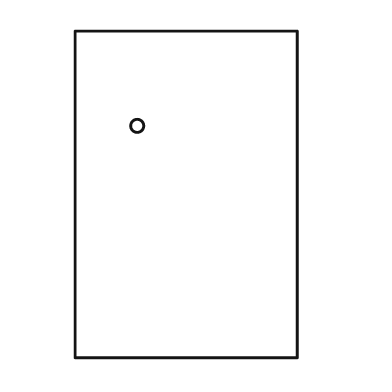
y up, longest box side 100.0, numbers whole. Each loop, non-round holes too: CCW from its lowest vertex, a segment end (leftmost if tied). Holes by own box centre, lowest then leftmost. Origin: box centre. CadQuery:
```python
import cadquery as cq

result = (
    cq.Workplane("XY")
    .moveTo(-34.0, -50.0)
    .lineTo(34.0, -50.0)
    .lineTo(34.0, 50.0)
    .lineTo(-34.0, 50.0)
    .close()
    .moveTo(-15.0, 21.0)
    .circle(2.0)
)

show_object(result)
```